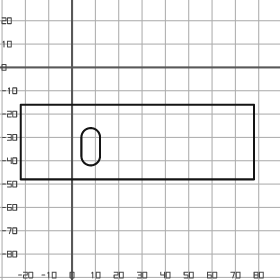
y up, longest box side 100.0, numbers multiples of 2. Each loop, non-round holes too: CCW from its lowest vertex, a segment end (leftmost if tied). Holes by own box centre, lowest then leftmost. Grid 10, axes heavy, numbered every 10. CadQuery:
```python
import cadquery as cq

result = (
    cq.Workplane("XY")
    .moveTo(-22.0, -48.0)
    .lineTo(78.0, -48.0)
    .lineTo(78.0, -16.0)
    .lineTo(-22.0, -16.0)
    .close()
    .moveTo(4.0, -38.0)
    .threePointArc((8.0, -42.0), (12.0, -38.0))
    .lineTo(12.0, -30.0)
    .threePointArc((8.0, -26.0), (4.0, -30.0))
    .close()
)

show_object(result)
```